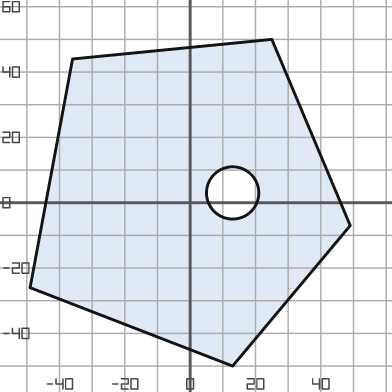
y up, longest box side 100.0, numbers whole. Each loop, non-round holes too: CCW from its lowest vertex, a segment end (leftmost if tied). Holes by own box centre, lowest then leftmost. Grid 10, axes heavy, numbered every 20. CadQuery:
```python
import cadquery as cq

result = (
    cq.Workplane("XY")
    .moveTo(13.0, -50.0)
    .lineTo(49.0, -7.0)
    .lineTo(25.0, 50.0)
    .lineTo(-36.0, 44.0)
    .lineTo(-49.0, -26.0)
    .close()
    .moveTo(13.0, 3.0)
    .circle(8.0)
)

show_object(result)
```